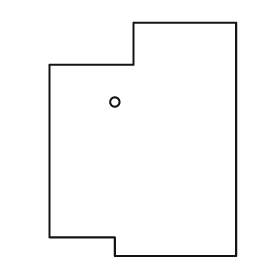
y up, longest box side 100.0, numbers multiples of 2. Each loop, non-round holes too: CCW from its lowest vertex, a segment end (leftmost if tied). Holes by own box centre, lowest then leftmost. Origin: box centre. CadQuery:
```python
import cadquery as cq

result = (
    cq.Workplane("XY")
    .moveTo(-12.0, -50.0)
    .lineTo(40.0, -50.0)
    .lineTo(40.0, 50.0)
    .lineTo(-4.0, 50.0)
    .lineTo(-4.0, 32.0)
    .lineTo(-40.0, 32.0)
    .lineTo(-40.0, -42.0)
    .lineTo(-12.0, -42.0)
    .close()
    .moveTo(-12.0, 16.0)
    .circle(2.0)
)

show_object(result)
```